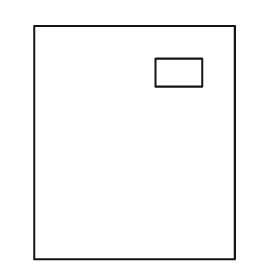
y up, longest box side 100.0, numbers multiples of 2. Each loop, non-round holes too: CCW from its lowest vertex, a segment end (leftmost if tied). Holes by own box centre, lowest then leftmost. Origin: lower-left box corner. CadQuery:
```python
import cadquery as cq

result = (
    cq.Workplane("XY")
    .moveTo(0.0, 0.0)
    .lineTo(86.0, 0.0)
    .lineTo(86.0, 100.0)
    .lineTo(0.0, 100.0)
    .close()
    .moveTo(52.0, 74.0)
    .lineTo(72.0, 74.0)
    .lineTo(72.0, 86.0)
    .lineTo(52.0, 86.0)
    .close()
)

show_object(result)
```